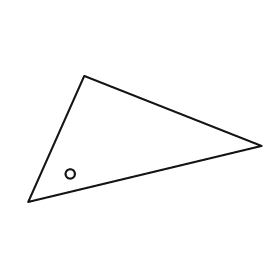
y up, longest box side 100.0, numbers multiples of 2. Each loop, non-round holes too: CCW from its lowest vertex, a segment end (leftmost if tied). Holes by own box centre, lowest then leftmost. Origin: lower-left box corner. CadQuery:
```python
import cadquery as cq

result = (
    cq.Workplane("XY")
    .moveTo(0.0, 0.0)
    .lineTo(100.0, 24.0)
    .lineTo(24.0, 54.0)
    .close()
    .moveTo(18.0, 12.0)
    .circle(2.0)
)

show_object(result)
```